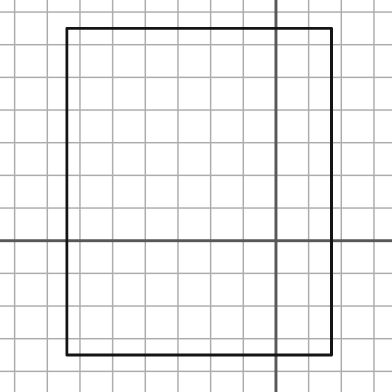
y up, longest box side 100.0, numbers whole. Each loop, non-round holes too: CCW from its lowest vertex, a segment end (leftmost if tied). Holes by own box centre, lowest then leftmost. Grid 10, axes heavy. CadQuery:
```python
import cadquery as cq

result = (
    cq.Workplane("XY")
    .moveTo(-64.0, -35.0)
    .lineTo(17.0, -35.0)
    .lineTo(17.0, 65.0)
    .lineTo(-64.0, 65.0)
    .close()
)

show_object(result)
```